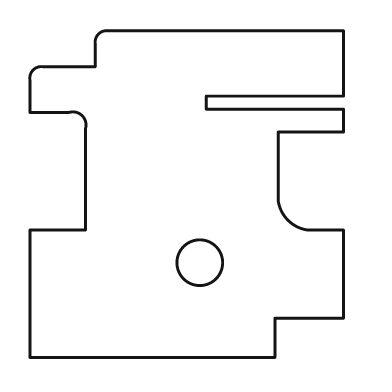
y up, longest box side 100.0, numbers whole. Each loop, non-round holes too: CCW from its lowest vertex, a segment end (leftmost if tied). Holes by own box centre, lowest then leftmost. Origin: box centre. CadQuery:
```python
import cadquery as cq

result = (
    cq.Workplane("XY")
    .moveTo(-48.0, -50.0)
    .lineTo(27.0, -50.0)
    .lineTo(27.0, -38.0)
    .lineTo(48.0, -38.0)
    .lineTo(48.0, -11.0)
    .lineTo(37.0, -11.0)
    .threePointArc((31.0, -8.0), (28.0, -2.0))
    .lineTo(28.0, 19.0)
    .lineTo(48.0, 19.0)
    .lineTo(48.0, 26.0)
    .lineTo(6.0, 26.0)
    .lineTo(6.0, 30.0)
    .lineTo(48.0, 30.0)
    .lineTo(48.0, 50.0)
    .lineTo(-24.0, 50.0)
    .threePointArc((-27.0, 49.0), (-28.0, 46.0))
    .lineTo(-28.0, 39.0)
    .lineTo(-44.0, 39.0)
    .threePointArc((-47.0, 38.0), (-48.0, 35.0))
    .lineTo(-48.0, 25.0)
    .lineTo(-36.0, 25.0)
    .threePointArc((-32.0, 24.0), (-31.0, 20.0))
    .lineTo(-31.0, -11.0)
    .lineTo(-48.0, -11.0)
    .close()
    .moveTo(4.0, -21.0)
    .circle(7.0)
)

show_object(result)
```